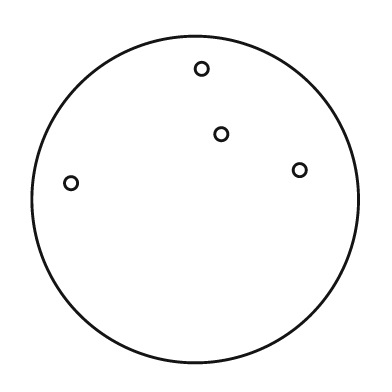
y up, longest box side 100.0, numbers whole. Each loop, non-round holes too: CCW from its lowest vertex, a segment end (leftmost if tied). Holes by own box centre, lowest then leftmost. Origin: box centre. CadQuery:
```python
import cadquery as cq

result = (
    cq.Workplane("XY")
    .moveTo(0.0, 0.0)
    .circle(50.0)
    .moveTo(-38.0, 5.0)
    .circle(2.0)
    .moveTo(32.0, 9.0)
    .circle(2.0)
    .moveTo(8.0, 20.0)
    .circle(2.0)
    .moveTo(2.0, 40.0)
    .circle(2.0)
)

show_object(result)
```